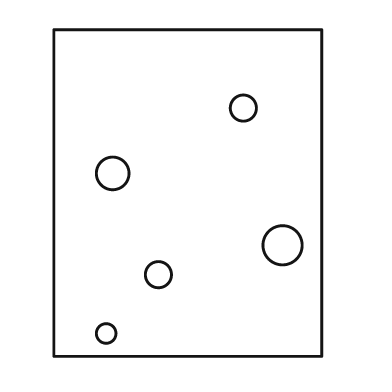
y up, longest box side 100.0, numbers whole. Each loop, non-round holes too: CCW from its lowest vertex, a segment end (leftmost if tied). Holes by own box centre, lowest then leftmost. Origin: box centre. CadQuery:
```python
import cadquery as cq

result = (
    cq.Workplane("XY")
    .moveTo(-41.0, -50.0)
    .lineTo(41.0, -50.0)
    .lineTo(41.0, 50.0)
    .lineTo(-41.0, 50.0)
    .close()
    .moveTo(-25.0, -43.0)
    .circle(3.0)
    .moveTo(-9.0, -25.0)
    .circle(4.0)
    .moveTo(29.0, -16.0)
    .circle(6.0)
    .moveTo(-23.0, 6.0)
    .circle(5.0)
    .moveTo(17.0, 26.0)
    .circle(4.0)
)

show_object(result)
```